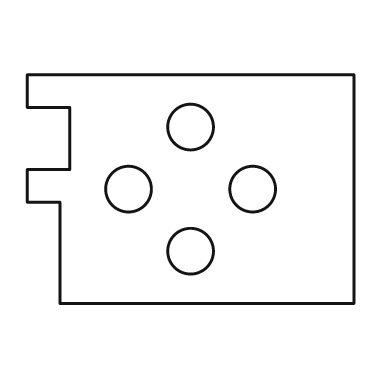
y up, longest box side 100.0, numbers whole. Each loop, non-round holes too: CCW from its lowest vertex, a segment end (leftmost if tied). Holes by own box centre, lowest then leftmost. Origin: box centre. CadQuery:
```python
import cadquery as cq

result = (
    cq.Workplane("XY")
    .moveTo(-40.0, -35.0)
    .lineTo(50.0, -35.0)
    .lineTo(50.0, 35.0)
    .lineTo(-50.0, 35.0)
    .lineTo(-50.0, 25.0)
    .lineTo(-37.0, 25.0)
    .lineTo(-37.0, 6.0)
    .lineTo(-50.0, 6.0)
    .lineTo(-50.0, -4.0)
    .lineTo(-40.0, -4.0)
    .close()
    .moveTo(0.0, -19.0)
    .circle(7.0)
    .moveTo(-19.0, 0.0)
    .circle(7.0)
    .moveTo(19.0, 0.0)
    .circle(7.0)
    .moveTo(0.0, 19.0)
    .circle(7.0)
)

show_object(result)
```